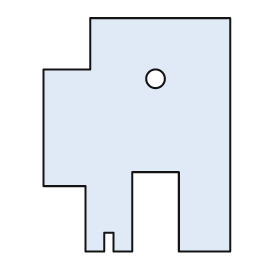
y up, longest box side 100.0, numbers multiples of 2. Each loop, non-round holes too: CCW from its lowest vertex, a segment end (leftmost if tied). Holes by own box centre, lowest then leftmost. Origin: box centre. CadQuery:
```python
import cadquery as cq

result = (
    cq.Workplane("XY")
    .moveTo(-22.0, -50.0)
    .lineTo(-14.0, -50.0)
    .lineTo(-14.0, -42.0)
    .lineTo(-10.0, -42.0)
    .lineTo(-10.0, -50.0)
    .lineTo(-2.0, -50.0)
    .lineTo(-2.0, -16.0)
    .lineTo(18.0, -16.0)
    .lineTo(18.0, -50.0)
    .lineTo(40.0, -50.0)
    .lineTo(40.0, 50.0)
    .lineTo(-20.0, 50.0)
    .lineTo(-20.0, 28.0)
    .lineTo(-40.0, 28.0)
    .lineTo(-40.0, -22.0)
    .lineTo(-22.0, -22.0)
    .close()
    .moveTo(8.0, 24.0)
    .circle(4.0)
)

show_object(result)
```